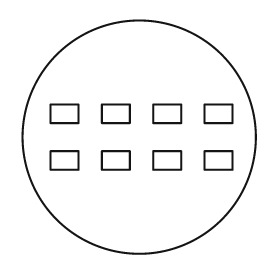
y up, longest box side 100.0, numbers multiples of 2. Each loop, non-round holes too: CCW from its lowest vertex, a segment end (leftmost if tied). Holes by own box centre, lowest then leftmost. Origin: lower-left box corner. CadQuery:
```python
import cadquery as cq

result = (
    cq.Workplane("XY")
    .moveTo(50.0, 50.0)
    .circle(50.0)
    .moveTo(12.0, 36.0)
    .lineTo(24.0, 36.0)
    .lineTo(24.0, 44.0)
    .lineTo(12.0, 44.0)
    .close()
    .moveTo(34.0, 36.0)
    .lineTo(46.0, 36.0)
    .lineTo(46.0, 44.0)
    .lineTo(34.0, 44.0)
    .close()
    .moveTo(56.0, 36.0)
    .lineTo(68.0, 36.0)
    .lineTo(68.0, 44.0)
    .lineTo(56.0, 44.0)
    .close()
    .moveTo(78.0, 36.0)
    .lineTo(90.0, 36.0)
    .lineTo(90.0, 44.0)
    .lineTo(78.0, 44.0)
    .close()
    .moveTo(12.0, 56.0)
    .lineTo(24.0, 56.0)
    .lineTo(24.0, 64.0)
    .lineTo(12.0, 64.0)
    .close()
    .moveTo(34.0, 56.0)
    .lineTo(46.0, 56.0)
    .lineTo(46.0, 64.0)
    .lineTo(34.0, 64.0)
    .close()
    .moveTo(56.0, 56.0)
    .lineTo(68.0, 56.0)
    .lineTo(68.0, 64.0)
    .lineTo(56.0, 64.0)
    .close()
    .moveTo(78.0, 56.0)
    .lineTo(90.0, 56.0)
    .lineTo(90.0, 64.0)
    .lineTo(78.0, 64.0)
    .close()
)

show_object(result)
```